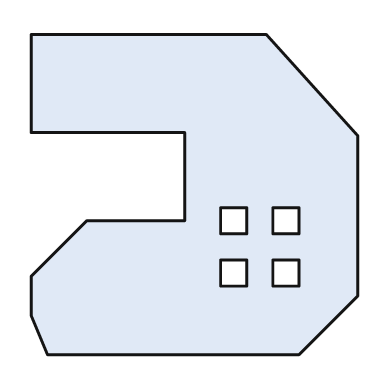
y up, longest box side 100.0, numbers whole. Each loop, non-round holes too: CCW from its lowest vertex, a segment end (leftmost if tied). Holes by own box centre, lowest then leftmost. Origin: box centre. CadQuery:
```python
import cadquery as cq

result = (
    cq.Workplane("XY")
    .moveTo(-45.0, -49.0)
    .lineTo(32.0, -49.0)
    .lineTo(50.0, -31.0)
    .lineTo(50.0, 18.0)
    .lineTo(22.0, 49.0)
    .lineTo(-50.0, 49.0)
    .lineTo(-50.0, 19.0)
    .lineTo(-3.0, 19.0)
    .lineTo(-3.0, -8.0)
    .lineTo(-33.0, -8.0)
    .lineTo(-50.0, -25.0)
    .lineTo(-50.0, -37.0)
    .close()
    .moveTo(8.0, -28.0)
    .lineTo(16.0, -28.0)
    .lineTo(16.0, -20.0)
    .lineTo(8.0, -20.0)
    .close()
    .moveTo(24.0, -28.0)
    .lineTo(32.0, -28.0)
    .lineTo(32.0, -20.0)
    .lineTo(24.0, -20.0)
    .close()
    .moveTo(8.0, -12.0)
    .lineTo(16.0, -12.0)
    .lineTo(16.0, -4.0)
    .lineTo(8.0, -4.0)
    .close()
    .moveTo(24.0, -12.0)
    .lineTo(32.0, -12.0)
    .lineTo(32.0, -4.0)
    .lineTo(24.0, -4.0)
    .close()
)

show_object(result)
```